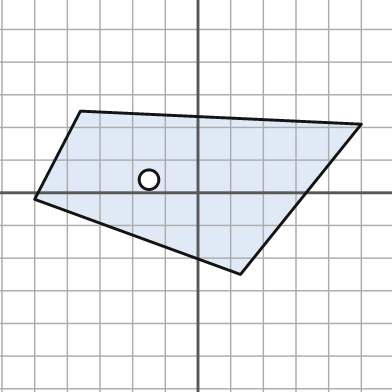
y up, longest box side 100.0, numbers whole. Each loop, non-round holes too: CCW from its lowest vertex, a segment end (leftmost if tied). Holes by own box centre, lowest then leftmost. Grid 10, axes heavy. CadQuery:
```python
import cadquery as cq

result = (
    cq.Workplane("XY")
    .moveTo(13.0, -25.0)
    .lineTo(50.0, 21.0)
    .lineTo(-36.0, 25.0)
    .lineTo(-50.0, -2.0)
    .close()
    .moveTo(-15.0, 4.0)
    .circle(3.0)
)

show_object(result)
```